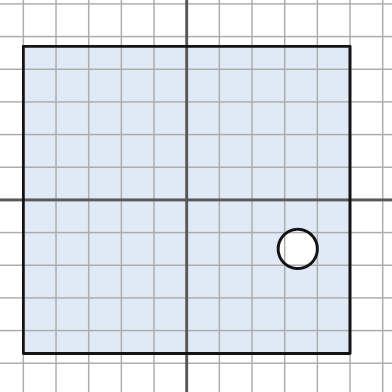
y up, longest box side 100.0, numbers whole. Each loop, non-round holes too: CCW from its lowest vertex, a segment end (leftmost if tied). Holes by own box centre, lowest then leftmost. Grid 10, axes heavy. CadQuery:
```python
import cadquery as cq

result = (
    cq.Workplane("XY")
    .moveTo(-50.0, -47.0)
    .lineTo(50.0, -47.0)
    .lineTo(50.0, 47.0)
    .lineTo(-50.0, 47.0)
    .close()
    .moveTo(34.0, -15.0)
    .circle(6.0)
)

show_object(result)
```